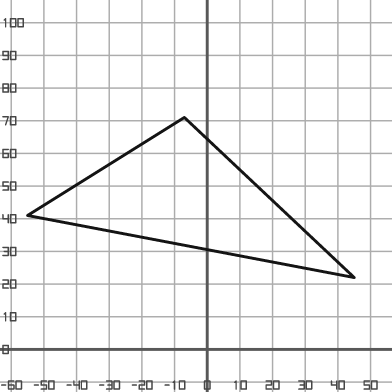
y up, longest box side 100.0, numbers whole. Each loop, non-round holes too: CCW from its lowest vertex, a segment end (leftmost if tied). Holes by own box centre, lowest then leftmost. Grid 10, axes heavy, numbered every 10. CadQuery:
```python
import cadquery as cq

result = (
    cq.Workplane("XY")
    .moveTo(45.0, 22.0)
    .lineTo(-7.0, 71.0)
    .lineTo(-55.0, 41.0)
    .close()
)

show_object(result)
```